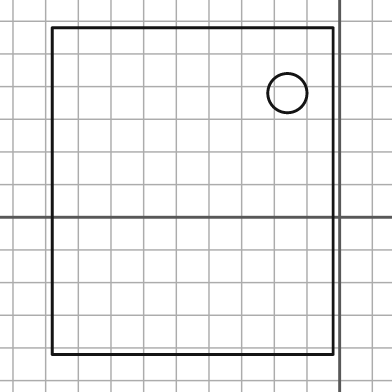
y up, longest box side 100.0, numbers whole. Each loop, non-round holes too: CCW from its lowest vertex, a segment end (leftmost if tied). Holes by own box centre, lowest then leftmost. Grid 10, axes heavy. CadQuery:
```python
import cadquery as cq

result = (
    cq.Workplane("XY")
    .moveTo(-88.0, -42.0)
    .lineTo(-2.0, -42.0)
    .lineTo(-2.0, 58.0)
    .lineTo(-88.0, 58.0)
    .close()
    .moveTo(-16.0, 38.0)
    .circle(6.0)
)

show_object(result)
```